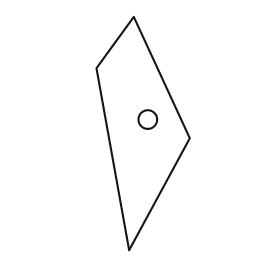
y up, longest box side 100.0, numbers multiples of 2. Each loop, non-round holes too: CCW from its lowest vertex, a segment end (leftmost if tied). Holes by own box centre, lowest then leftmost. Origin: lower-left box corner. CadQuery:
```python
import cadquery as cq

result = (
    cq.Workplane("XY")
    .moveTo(14.0, 0.0)
    .lineTo(40.0, 48.0)
    .lineTo(16.0, 100.0)
    .lineTo(0.0, 78.0)
    .close()
    .moveTo(22.0, 56.0)
    .circle(4.0)
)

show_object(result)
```